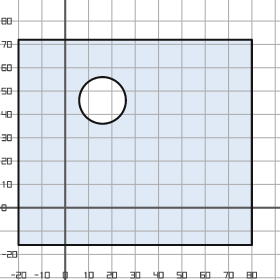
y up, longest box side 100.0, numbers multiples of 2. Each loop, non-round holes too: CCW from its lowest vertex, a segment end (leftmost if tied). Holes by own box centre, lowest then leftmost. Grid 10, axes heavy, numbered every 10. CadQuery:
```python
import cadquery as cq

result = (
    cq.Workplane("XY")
    .moveTo(-20.0, -16.0)
    .lineTo(80.0, -16.0)
    .lineTo(80.0, 72.0)
    .lineTo(-20.0, 72.0)
    .close()
    .moveTo(16.0, 46.0)
    .circle(10.0)
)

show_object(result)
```